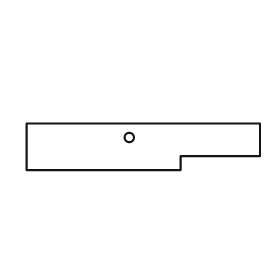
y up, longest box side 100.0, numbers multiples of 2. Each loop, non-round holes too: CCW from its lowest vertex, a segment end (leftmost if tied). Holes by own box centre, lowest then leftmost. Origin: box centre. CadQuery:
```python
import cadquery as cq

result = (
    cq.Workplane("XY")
    .moveTo(-50.0, -10.0)
    .lineTo(16.0, -10.0)
    .lineTo(16.0, -4.0)
    .lineTo(50.0, -4.0)
    .lineTo(50.0, 10.0)
    .lineTo(-50.0, 10.0)
    .close()
    .moveTo(-6.0, 4.0)
    .circle(2.0)
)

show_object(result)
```